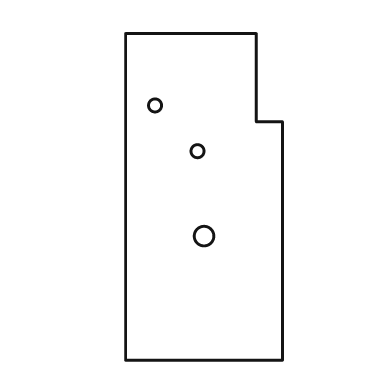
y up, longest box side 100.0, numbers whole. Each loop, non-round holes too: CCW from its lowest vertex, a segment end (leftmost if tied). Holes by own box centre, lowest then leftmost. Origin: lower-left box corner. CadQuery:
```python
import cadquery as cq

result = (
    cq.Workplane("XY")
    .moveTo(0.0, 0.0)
    .lineTo(48.0, 0.0)
    .lineTo(48.0, 73.0)
    .lineTo(40.0, 73.0)
    .lineTo(40.0, 100.0)
    .lineTo(0.0, 100.0)
    .close()
    .moveTo(24.0, 38.0)
    .circle(3.0)
    .moveTo(22.0, 64.0)
    .circle(2.0)
    .moveTo(9.0, 78.0)
    .circle(2.0)
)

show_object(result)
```